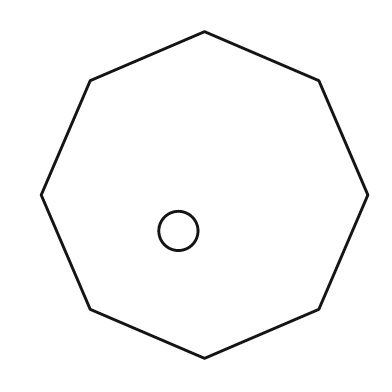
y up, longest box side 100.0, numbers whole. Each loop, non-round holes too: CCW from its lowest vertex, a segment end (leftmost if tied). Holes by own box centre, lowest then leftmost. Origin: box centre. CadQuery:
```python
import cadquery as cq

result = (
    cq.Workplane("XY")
    .moveTo(0.0, -50.0)
    .lineTo(35.0, -35.0)
    .lineTo(50.0, 0.0)
    .lineTo(35.0, 35.0)
    .lineTo(0.0, 50.0)
    .lineTo(-35.0, 35.0)
    .lineTo(-50.0, 0.0)
    .lineTo(-35.0, -35.0)
    .close()
    .moveTo(-8.0, -11.0)
    .circle(6.0)
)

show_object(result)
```